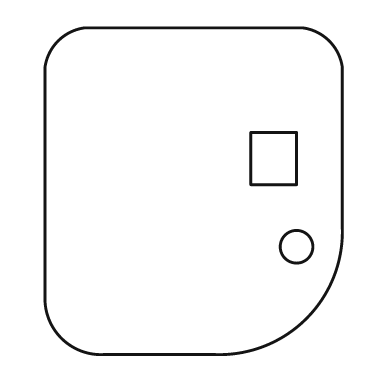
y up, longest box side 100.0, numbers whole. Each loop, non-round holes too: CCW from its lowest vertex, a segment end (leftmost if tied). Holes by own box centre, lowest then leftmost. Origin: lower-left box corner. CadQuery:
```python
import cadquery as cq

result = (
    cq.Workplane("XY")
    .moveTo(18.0, 0.0)
    .lineTo(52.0, 0.0)
    .threePointArc((80.0, 11.0), (91.0, 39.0))
    .lineTo(91.0, 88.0)
    .threePointArc((87.0, 96.0), (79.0, 100.0))
    .lineTo(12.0, 100.0)
    .threePointArc((4.0, 96.0), (0.0, 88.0))
    .lineTo(0.0, 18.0)
    .threePointArc((5.0, 5.0), (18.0, 0.0))
    .close()
    .moveTo(77.0, 33.0)
    .circle(5.0)
    .moveTo(63.0, 52.0)
    .lineTo(77.0, 52.0)
    .lineTo(77.0, 68.0)
    .lineTo(63.0, 68.0)
    .close()
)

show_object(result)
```